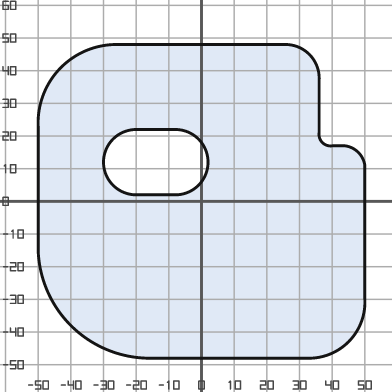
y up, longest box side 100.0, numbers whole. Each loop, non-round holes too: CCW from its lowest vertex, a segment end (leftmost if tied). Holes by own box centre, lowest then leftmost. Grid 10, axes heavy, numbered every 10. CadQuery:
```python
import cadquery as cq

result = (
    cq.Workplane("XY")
    .moveTo(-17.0, -48.0)
    .lineTo(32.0, -48.0)
    .threePointArc((45.0, -43.0), (50.0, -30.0))
    .lineTo(50.0, 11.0)
    .threePointArc((48.0, 15.0), (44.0, 17.0))
    .lineTo(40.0, 17.0)
    .threePointArc((37.0, 18.0), (36.0, 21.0))
    .lineTo(36.0, 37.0)
    .threePointArc((33.0, 45.0), (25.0, 48.0))
    .lineTo(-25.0, 48.0)
    .threePointArc((-43.0, 41.0), (-50.0, 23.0))
    .lineTo(-50.0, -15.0)
    .threePointArc((-40.0, -38.0), (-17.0, -48.0))
    .close()
    .moveTo(-20.0, 2.0)
    .lineTo(-8.0, 2.0)
    .threePointArc((2.0, 12.0), (-8.0, 22.0))
    .lineTo(-20.0, 22.0)
    .threePointArc((-30.0, 12.0), (-20.0, 2.0))
    .close()
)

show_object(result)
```